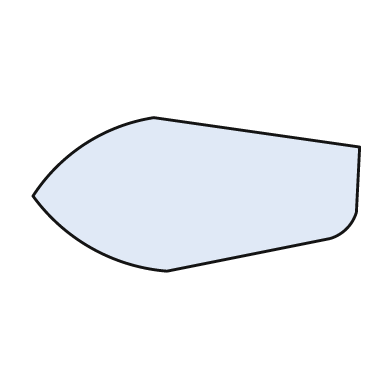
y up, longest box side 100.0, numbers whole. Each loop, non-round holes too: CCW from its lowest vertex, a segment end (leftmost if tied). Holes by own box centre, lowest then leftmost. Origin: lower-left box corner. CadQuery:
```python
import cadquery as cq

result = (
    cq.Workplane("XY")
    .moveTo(41.0, 0.0)
    .lineTo(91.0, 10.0)
    .threePointArc((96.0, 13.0), (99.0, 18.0))
    .lineTo(100.0, 38.0)
    .lineTo(37.0, 47.0)
    .threePointArc((16.0, 39.0), (0.0, 23.0))
    .threePointArc((18.0, 7.0), (41.0, 0.0))
    .close()
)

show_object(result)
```